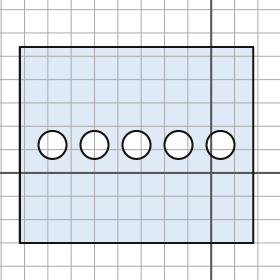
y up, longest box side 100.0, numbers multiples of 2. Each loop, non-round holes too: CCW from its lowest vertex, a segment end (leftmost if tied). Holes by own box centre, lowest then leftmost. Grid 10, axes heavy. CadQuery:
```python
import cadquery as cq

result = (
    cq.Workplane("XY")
    .moveTo(-82.0, -30.0)
    .lineTo(18.0, -30.0)
    .lineTo(18.0, 54.0)
    .lineTo(-82.0, 54.0)
    .close()
    .moveTo(-68.0, 12.0)
    .circle(6.0)
    .moveTo(-50.0, 12.0)
    .circle(6.0)
    .moveTo(-32.0, 12.0)
    .circle(6.0)
    .moveTo(-14.0, 12.0)
    .circle(6.0)
    .moveTo(4.0, 12.0)
    .circle(6.0)
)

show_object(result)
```